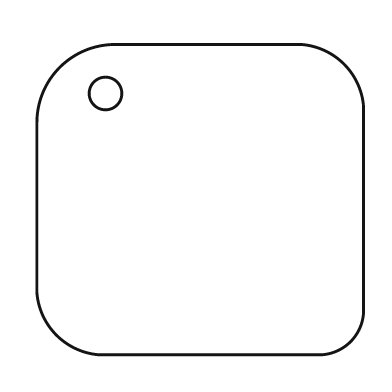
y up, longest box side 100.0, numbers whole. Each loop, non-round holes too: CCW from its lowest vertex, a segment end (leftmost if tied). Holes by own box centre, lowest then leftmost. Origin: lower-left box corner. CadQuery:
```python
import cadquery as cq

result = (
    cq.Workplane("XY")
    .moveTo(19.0, 0.0)
    .lineTo(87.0, 0.0)
    .threePointArc((96.0, 4.0), (100.0, 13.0))
    .lineTo(100.0, 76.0)
    .threePointArc((94.0, 89.0), (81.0, 95.0))
    .lineTo(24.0, 95.0)
    .threePointArc((7.0, 88.0), (0.0, 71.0))
    .lineTo(0.0, 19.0)
    .threePointArc((6.0, 6.0), (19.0, 0.0))
    .close()
    .moveTo(21.0, 80.0)
    .circle(5.0)
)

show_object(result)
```